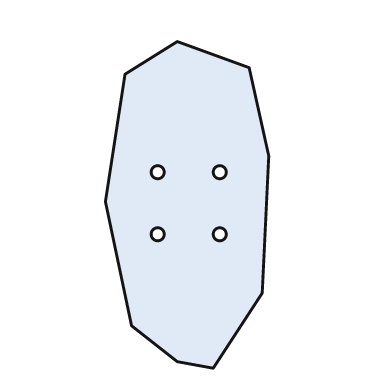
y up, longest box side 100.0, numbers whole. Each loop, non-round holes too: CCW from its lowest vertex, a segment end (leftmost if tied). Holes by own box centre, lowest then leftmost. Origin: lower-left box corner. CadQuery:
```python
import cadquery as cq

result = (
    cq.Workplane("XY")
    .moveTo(33.0, 0.0)
    .lineTo(48.0, 23.0)
    .lineTo(50.0, 65.0)
    .lineTo(44.0, 92.0)
    .lineTo(22.0, 100.0)
    .lineTo(6.0, 90.0)
    .lineTo(0.0, 51.0)
    .lineTo(8.0, 13.0)
    .lineTo(22.0, 2.0)
    .close()
    .moveTo(16.0, 41.0)
    .circle(2.0)
    .moveTo(35.0, 41.0)
    .circle(2.0)
    .moveTo(16.0, 60.0)
    .circle(2.0)
    .moveTo(35.0, 60.0)
    .circle(2.0)
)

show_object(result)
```